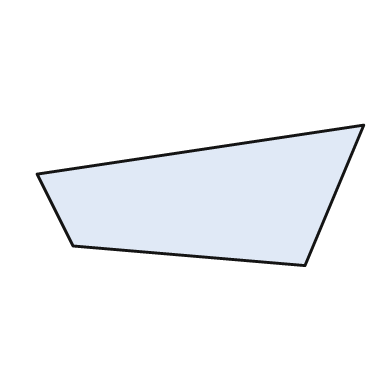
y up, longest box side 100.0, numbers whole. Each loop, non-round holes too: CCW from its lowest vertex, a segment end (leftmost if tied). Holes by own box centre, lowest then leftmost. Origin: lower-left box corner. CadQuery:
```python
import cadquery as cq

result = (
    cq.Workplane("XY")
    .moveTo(82.0, 0.0)
    .lineTo(100.0, 43.0)
    .lineTo(0.0, 28.0)
    .lineTo(11.0, 6.0)
    .close()
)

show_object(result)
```